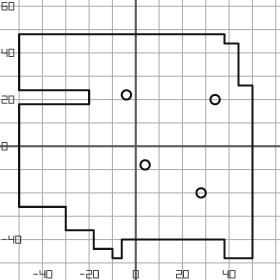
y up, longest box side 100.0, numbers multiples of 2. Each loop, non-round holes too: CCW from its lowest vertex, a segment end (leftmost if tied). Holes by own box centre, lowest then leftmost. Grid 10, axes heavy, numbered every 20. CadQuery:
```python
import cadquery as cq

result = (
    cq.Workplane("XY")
    .moveTo(-10.0, -48.0)
    .lineTo(-6.0, -48.0)
    .lineTo(-6.0, -40.0)
    .lineTo(38.0, -40.0)
    .lineTo(38.0, -48.0)
    .lineTo(50.0, -48.0)
    .lineTo(50.0, 26.0)
    .lineTo(44.0, 26.0)
    .lineTo(44.0, 44.0)
    .lineTo(38.0, 44.0)
    .lineTo(38.0, 48.0)
    .lineTo(-50.0, 48.0)
    .lineTo(-50.0, 24.0)
    .lineTo(-20.0, 24.0)
    .lineTo(-20.0, 18.0)
    .lineTo(-50.0, 18.0)
    .lineTo(-50.0, -26.0)
    .lineTo(-30.0, -26.0)
    .lineTo(-30.0, -36.0)
    .lineTo(-18.0, -36.0)
    .lineTo(-18.0, -44.0)
    .lineTo(-10.0, -44.0)
    .close()
    .moveTo(28.0, -20.0)
    .circle(2.0)
    .moveTo(4.0, -8.0)
    .circle(2.0)
    .moveTo(34.0, 20.0)
    .circle(2.0)
    .moveTo(-4.0, 22.0)
    .circle(2.0)
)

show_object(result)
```